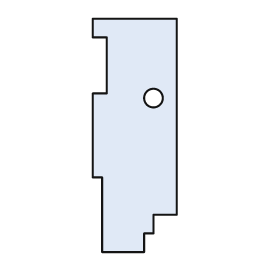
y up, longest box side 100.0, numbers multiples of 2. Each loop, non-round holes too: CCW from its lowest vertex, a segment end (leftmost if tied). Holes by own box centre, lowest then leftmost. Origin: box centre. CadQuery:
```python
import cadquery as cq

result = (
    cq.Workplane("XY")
    .moveTo(-14.0, -50.0)
    .lineTo(4.0, -50.0)
    .lineTo(4.0, -42.0)
    .lineTo(8.0, -42.0)
    .lineTo(8.0, -34.0)
    .lineTo(18.0, -34.0)
    .lineTo(18.0, 50.0)
    .lineTo(-18.0, 50.0)
    .lineTo(-18.0, 42.0)
    .lineTo(-12.0, 42.0)
    .lineTo(-12.0, 18.0)
    .lineTo(-18.0, 18.0)
    .lineTo(-18.0, -18.0)
    .lineTo(-14.0, -18.0)
    .close()
    .moveTo(8.0, 16.0)
    .circle(4.0)
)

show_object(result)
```